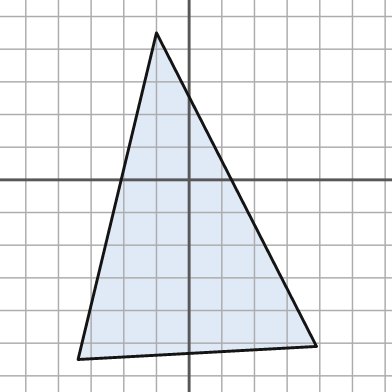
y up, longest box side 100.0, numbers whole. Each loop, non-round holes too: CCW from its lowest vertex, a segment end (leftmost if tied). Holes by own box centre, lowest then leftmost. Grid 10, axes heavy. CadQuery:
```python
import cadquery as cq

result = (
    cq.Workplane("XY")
    .moveTo(-34.0, -55.0)
    .lineTo(39.0, -51.0)
    .lineTo(-10.0, 45.0)
    .close()
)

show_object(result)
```